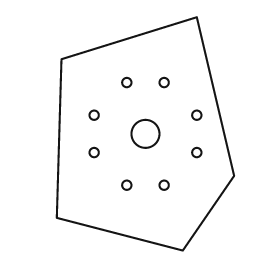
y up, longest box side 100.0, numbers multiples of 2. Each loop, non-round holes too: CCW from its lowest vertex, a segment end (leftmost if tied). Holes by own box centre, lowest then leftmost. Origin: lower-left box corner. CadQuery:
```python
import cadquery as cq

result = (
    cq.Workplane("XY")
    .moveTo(54.0, 0.0)
    .lineTo(76.0, 32.0)
    .lineTo(60.0, 100.0)
    .lineTo(2.0, 82.0)
    .lineTo(0.0, 14.0)
    .close()
    .moveTo(30.0, 28.0)
    .circle(2.0)
    .moveTo(46.0, 28.0)
    .circle(2.0)
    .moveTo(16.0, 42.0)
    .circle(2.0)
    .moveTo(60.0, 42.0)
    .circle(2.0)
    .moveTo(38.0, 50.0)
    .circle(6.0)
    .moveTo(16.0, 58.0)
    .circle(2.0)
    .moveTo(60.0, 58.0)
    .circle(2.0)
    .moveTo(30.0, 72.0)
    .circle(2.0)
    .moveTo(46.0, 72.0)
    .circle(2.0)
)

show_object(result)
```